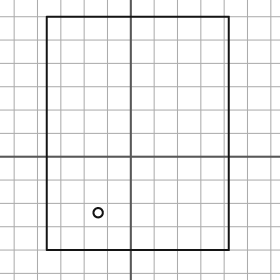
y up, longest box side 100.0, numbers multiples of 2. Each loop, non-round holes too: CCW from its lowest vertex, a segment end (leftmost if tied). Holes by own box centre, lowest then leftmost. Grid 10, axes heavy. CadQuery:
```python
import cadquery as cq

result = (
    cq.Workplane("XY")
    .moveTo(-36.0, -40.0)
    .lineTo(42.0, -40.0)
    .lineTo(42.0, 60.0)
    .lineTo(-36.0, 60.0)
    .close()
    .moveTo(-14.0, -24.0)
    .circle(2.0)
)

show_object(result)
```